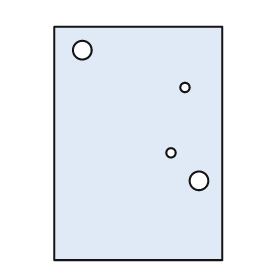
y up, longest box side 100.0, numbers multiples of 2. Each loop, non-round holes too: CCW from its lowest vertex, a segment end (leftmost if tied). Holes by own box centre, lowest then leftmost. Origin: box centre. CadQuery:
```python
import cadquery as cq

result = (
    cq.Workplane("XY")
    .moveTo(-36.0, -50.0)
    .lineTo(36.0, -50.0)
    .lineTo(36.0, 50.0)
    .lineTo(-36.0, 50.0)
    .close()
    .moveTo(26.0, -16.0)
    .circle(4.0)
    .moveTo(14.0, -4.0)
    .circle(2.0)
    .moveTo(20.0, 24.0)
    .circle(2.0)
    .moveTo(-24.0, 40.0)
    .circle(4.0)
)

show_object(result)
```